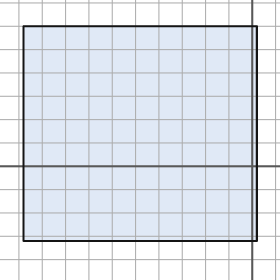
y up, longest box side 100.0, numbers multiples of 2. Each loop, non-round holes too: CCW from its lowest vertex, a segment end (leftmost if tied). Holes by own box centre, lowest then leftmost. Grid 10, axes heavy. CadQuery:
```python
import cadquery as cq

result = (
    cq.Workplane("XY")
    .moveTo(-98.0, -32.0)
    .lineTo(2.0, -32.0)
    .lineTo(2.0, 60.0)
    .lineTo(-98.0, 60.0)
    .close()
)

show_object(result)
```